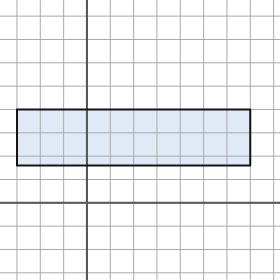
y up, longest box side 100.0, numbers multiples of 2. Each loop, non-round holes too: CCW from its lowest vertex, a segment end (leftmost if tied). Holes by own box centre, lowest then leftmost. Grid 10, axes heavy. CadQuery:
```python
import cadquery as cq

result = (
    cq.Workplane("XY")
    .moveTo(-30.0, 16.0)
    .lineTo(70.0, 16.0)
    .lineTo(70.0, 40.0)
    .lineTo(-30.0, 40.0)
    .close()
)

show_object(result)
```